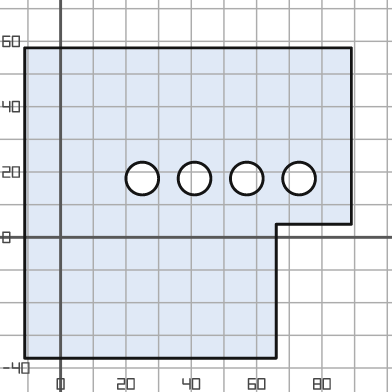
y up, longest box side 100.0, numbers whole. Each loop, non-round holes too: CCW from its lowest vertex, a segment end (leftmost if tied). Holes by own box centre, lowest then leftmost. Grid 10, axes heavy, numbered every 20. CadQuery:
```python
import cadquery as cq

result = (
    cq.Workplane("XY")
    .moveTo(-11.0, -37.0)
    .lineTo(66.0, -37.0)
    .lineTo(66.0, 4.0)
    .lineTo(89.0, 4.0)
    .lineTo(89.0, 58.0)
    .lineTo(-11.0, 58.0)
    .close()
    .moveTo(25.0, 18.0)
    .circle(5.0)
    .moveTo(41.0, 18.0)
    .circle(5.0)
    .moveTo(57.0, 18.0)
    .circle(5.0)
    .moveTo(73.0, 18.0)
    .circle(5.0)
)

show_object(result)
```